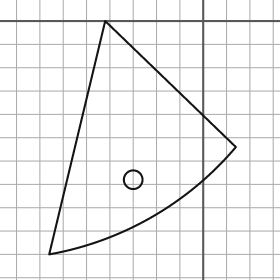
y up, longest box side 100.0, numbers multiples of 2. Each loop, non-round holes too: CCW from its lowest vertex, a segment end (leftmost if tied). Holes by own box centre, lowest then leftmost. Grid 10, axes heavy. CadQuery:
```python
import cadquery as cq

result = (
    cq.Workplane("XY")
    .moveTo(-66.0, -100.0)
    .threePointArc((-22.0, -84.0), (14.0, -54.0))
    .lineTo(-42.0, 0.0)
    .close()
    .moveTo(-30.0, -68.0)
    .circle(4.0)
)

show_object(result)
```